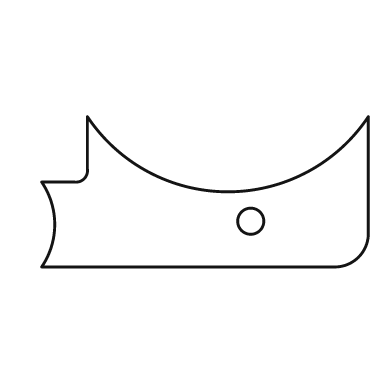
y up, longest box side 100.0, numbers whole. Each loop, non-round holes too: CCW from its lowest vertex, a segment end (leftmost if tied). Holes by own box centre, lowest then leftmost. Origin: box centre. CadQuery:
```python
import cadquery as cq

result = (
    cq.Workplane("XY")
    .moveTo(-50.0, -23.0)
    .lineTo(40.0, -23.0)
    .threePointArc((47.0, -20.0), (50.0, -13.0))
    .lineTo(50.0, 23.0)
    .threePointArc((7.0, 0.0), (-36.0, 23.0))
    .lineTo(-36.0, 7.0)
    .threePointArc((-37.0, 4.0), (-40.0, 3.0))
    .lineTo(-50.0, 3.0)
    .threePointArc((-46.0, -10.0), (-50.0, -23.0))
    .close()
    .moveTo(14.0, -9.0)
    .circle(4.0)
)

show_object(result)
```